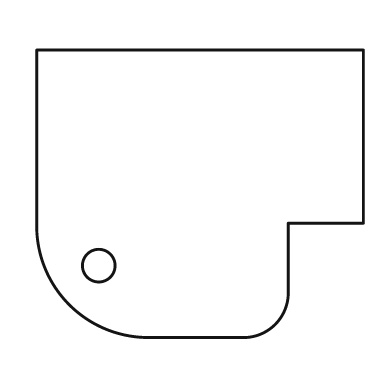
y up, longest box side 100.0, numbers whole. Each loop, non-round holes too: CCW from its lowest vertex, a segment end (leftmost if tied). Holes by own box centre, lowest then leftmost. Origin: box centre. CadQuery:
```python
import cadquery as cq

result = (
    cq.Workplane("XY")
    .moveTo(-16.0, -44.0)
    .lineTo(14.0, -44.0)
    .threePointArc((23.0, -40.0), (27.0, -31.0))
    .lineTo(27.0, -9.0)
    .lineTo(50.0, -9.0)
    .lineTo(50.0, 44.0)
    .lineTo(-50.0, 44.0)
    .lineTo(-50.0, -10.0)
    .threePointArc((-40.0, -34.0), (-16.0, -44.0))
    .close()
    .moveTo(-31.0, -22.0)
    .circle(5.0)
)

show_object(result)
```